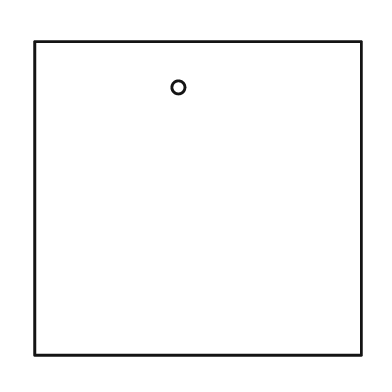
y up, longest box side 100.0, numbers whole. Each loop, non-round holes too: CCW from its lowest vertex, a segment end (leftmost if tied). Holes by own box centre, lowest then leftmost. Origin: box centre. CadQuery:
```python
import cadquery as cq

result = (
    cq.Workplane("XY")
    .moveTo(-50.0, -48.0)
    .lineTo(50.0, -48.0)
    .lineTo(50.0, 48.0)
    .lineTo(-50.0, 48.0)
    .close()
    .moveTo(-6.0, 34.0)
    .circle(2.0)
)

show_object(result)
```